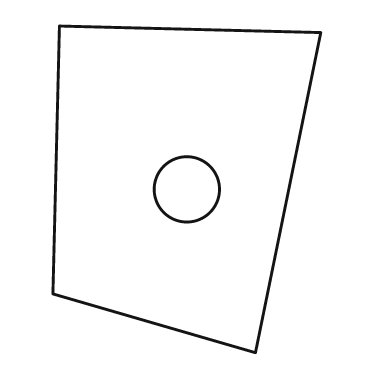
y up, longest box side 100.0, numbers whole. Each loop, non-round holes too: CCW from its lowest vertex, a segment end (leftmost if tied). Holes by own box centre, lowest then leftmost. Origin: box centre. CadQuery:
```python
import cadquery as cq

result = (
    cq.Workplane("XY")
    .moveTo(21.0, -50.0)
    .lineTo(41.0, 48.0)
    .lineTo(-39.0, 50.0)
    .lineTo(-41.0, -32.0)
    .close()
    .moveTo(0.0, 0.0)
    .circle(10.0)
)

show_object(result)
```